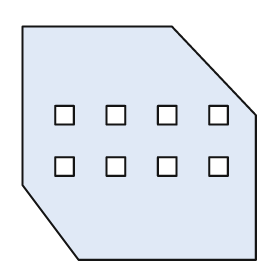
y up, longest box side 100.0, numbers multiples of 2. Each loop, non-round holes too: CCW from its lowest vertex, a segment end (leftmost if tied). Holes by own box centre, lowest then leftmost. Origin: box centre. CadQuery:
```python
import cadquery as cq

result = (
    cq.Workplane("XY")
    .moveTo(-26.0, -50.0)
    .lineTo(50.0, -50.0)
    .lineTo(50.0, 12.0)
    .lineTo(14.0, 50.0)
    .lineTo(-50.0, 50.0)
    .lineTo(-50.0, -18.0)
    .close()
    .moveTo(-36.0, -14.0)
    .lineTo(-28.0, -14.0)
    .lineTo(-28.0, -6.0)
    .lineTo(-36.0, -6.0)
    .close()
    .moveTo(-14.0, -14.0)
    .lineTo(-6.0, -14.0)
    .lineTo(-6.0, -6.0)
    .lineTo(-14.0, -6.0)
    .close()
    .moveTo(8.0, -14.0)
    .lineTo(16.0, -14.0)
    .lineTo(16.0, -6.0)
    .lineTo(8.0, -6.0)
    .close()
    .moveTo(30.0, -14.0)
    .lineTo(38.0, -14.0)
    .lineTo(38.0, -6.0)
    .lineTo(30.0, -6.0)
    .close()
    .moveTo(-36.0, 8.0)
    .lineTo(-28.0, 8.0)
    .lineTo(-28.0, 16.0)
    .lineTo(-36.0, 16.0)
    .close()
    .moveTo(-14.0, 8.0)
    .lineTo(-6.0, 8.0)
    .lineTo(-6.0, 16.0)
    .lineTo(-14.0, 16.0)
    .close()
    .moveTo(8.0, 8.0)
    .lineTo(16.0, 8.0)
    .lineTo(16.0, 16.0)
    .lineTo(8.0, 16.0)
    .close()
    .moveTo(30.0, 8.0)
    .lineTo(38.0, 8.0)
    .lineTo(38.0, 16.0)
    .lineTo(30.0, 16.0)
    .close()
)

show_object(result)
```